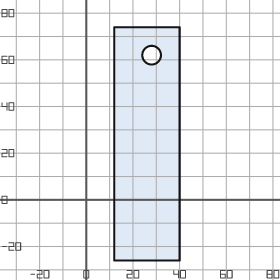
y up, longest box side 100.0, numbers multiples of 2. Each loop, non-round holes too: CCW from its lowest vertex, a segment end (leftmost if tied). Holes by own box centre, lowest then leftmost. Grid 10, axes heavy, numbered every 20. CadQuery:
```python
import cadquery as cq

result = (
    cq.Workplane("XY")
    .moveTo(12.0, -26.0)
    .lineTo(40.0, -26.0)
    .lineTo(40.0, 74.0)
    .lineTo(12.0, 74.0)
    .close()
    .moveTo(28.0, 62.0)
    .circle(4.0)
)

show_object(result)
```